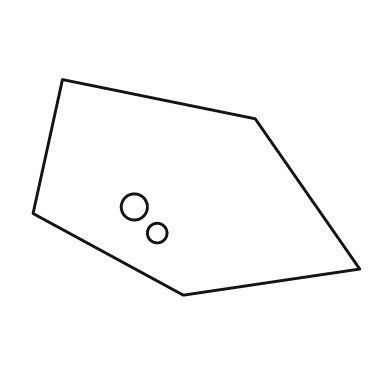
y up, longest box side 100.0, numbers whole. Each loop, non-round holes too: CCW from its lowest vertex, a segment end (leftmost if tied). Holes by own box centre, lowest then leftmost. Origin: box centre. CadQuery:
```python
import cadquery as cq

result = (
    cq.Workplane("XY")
    .moveTo(-4.0, -33.0)
    .lineTo(50.0, -25.0)
    .lineTo(18.0, 21.0)
    .lineTo(-41.0, 33.0)
    .lineTo(-50.0, -8.0)
    .close()
    .moveTo(-12.0, -14.0)
    .circle(3.0)
    .moveTo(-19.0, -6.0)
    .circle(4.0)
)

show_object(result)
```